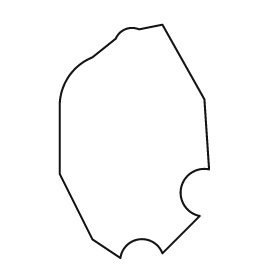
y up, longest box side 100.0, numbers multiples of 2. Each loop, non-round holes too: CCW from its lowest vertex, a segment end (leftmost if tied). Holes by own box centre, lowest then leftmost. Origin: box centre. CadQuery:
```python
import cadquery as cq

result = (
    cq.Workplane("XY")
    .moveTo(-6.0, -50.0)
    .threePointArc((2.0, -42.0), (12.0, -48.0))
    .lineTo(28.0, -32.0)
    .threePointArc((20.0, -20.0), (32.0, -12.0))
    .lineTo(30.0, 18.0)
    .lineTo(12.0, 50.0)
    .lineTo(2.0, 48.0)
    .threePointArc((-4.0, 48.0), (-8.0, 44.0))
    .lineTo(-18.0, 36.0)
    .threePointArc((-28.0, 28.0), (-32.0, 16.0))
    .lineTo(-32.0, -14.0)
    .lineTo(-18.0, -42.0)
    .close()
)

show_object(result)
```